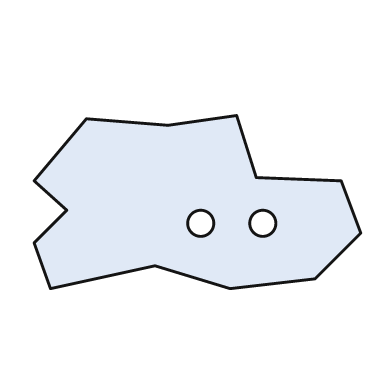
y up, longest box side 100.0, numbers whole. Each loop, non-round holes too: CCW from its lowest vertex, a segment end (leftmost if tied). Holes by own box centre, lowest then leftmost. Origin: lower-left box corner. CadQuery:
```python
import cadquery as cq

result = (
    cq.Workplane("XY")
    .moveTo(5.0, 0.0)
    .lineTo(37.0, 7.0)
    .lineTo(60.0, 0.0)
    .lineTo(86.0, 3.0)
    .lineTo(100.0, 17.0)
    .lineTo(94.0, 33.0)
    .lineTo(68.0, 34.0)
    .lineTo(62.0, 53.0)
    .lineTo(41.0, 50.0)
    .lineTo(16.0, 52.0)
    .lineTo(0.0, 33.0)
    .lineTo(10.0, 24.0)
    .lineTo(0.0, 14.0)
    .close()
    .moveTo(51.0, 20.0)
    .circle(4.0)
    .moveTo(70.0, 20.0)
    .circle(4.0)
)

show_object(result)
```